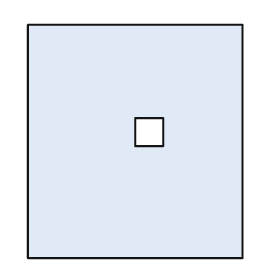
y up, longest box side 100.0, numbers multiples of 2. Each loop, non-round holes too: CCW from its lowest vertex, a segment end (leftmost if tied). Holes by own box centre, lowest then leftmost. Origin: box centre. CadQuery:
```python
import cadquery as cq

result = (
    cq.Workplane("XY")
    .moveTo(-46.0, -50.0)
    .lineTo(46.0, -50.0)
    .lineTo(46.0, 50.0)
    .lineTo(-46.0, 50.0)
    .close()
    .moveTo(0.0, -2.0)
    .lineTo(12.0, -2.0)
    .lineTo(12.0, 10.0)
    .lineTo(0.0, 10.0)
    .close()
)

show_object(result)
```